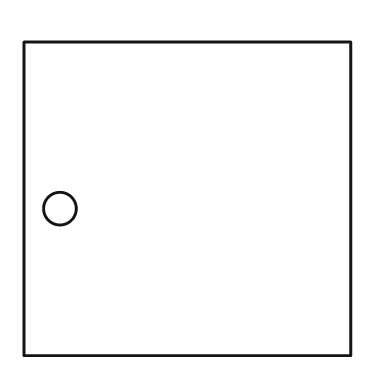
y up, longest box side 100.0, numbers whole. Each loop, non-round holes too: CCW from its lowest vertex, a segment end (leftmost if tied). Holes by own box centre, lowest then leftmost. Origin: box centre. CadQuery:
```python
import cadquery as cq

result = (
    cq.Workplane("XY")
    .moveTo(-50.0, -48.0)
    .lineTo(50.0, -48.0)
    .lineTo(50.0, 48.0)
    .lineTo(-50.0, 48.0)
    .close()
    .moveTo(-39.0, -3.0)
    .circle(5.0)
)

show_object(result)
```